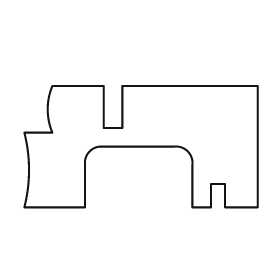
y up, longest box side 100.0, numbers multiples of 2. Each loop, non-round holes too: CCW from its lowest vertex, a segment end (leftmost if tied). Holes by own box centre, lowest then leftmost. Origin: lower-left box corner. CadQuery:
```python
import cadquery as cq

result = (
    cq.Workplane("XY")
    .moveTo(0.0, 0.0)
    .lineTo(26.0, 0.0)
    .lineTo(26.0, 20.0)
    .threePointArc((28.0, 24.0), (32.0, 26.0))
    .lineTo(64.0, 26.0)
    .threePointArc((70.0, 24.0), (72.0, 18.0))
    .lineTo(72.0, 0.0)
    .lineTo(80.0, 0.0)
    .lineTo(80.0, 10.0)
    .lineTo(86.0, 10.0)
    .lineTo(86.0, 0.0)
    .lineTo(100.0, 0.0)
    .lineTo(100.0, 52.0)
    .lineTo(42.0, 52.0)
    .lineTo(42.0, 34.0)
    .lineTo(34.0, 34.0)
    .lineTo(34.0, 52.0)
    .lineTo(12.0, 52.0)
    .threePointArc((10.0, 42.0), (12.0, 32.0))
    .lineTo(0.0, 32.0)
    .threePointArc((2.0, 16.0), (0.0, 0.0))
    .close()
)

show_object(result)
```